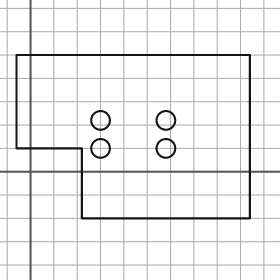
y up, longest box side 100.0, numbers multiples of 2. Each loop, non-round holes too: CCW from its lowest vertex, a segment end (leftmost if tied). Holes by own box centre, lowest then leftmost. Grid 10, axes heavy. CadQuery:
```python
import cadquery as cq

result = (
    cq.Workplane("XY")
    .moveTo(22.0, -20.0)
    .lineTo(94.0, -20.0)
    .lineTo(94.0, 50.0)
    .lineTo(-6.0, 50.0)
    .lineTo(-6.0, 10.0)
    .lineTo(22.0, 10.0)
    .close()
    .moveTo(30.0, 10.0)
    .circle(4.0)
    .moveTo(58.0, 10.0)
    .circle(4.0)
    .moveTo(30.0, 22.0)
    .circle(4.0)
    .moveTo(58.0, 22.0)
    .circle(4.0)
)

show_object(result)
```